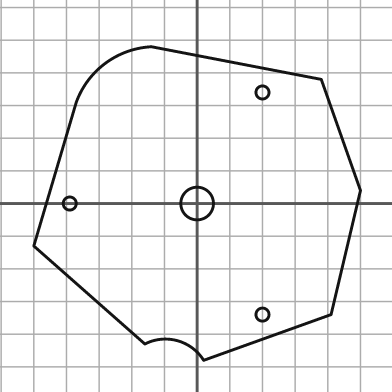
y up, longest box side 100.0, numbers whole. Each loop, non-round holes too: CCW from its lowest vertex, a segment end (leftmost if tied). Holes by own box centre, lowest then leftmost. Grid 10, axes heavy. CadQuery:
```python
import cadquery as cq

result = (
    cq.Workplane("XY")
    .moveTo(2.0, -48.0)
    .lineTo(41.0, -34.0)
    .lineTo(50.0, 4.0)
    .lineTo(38.0, 38.0)
    .lineTo(-14.0, 48.0)
    .threePointArc((-28.0, 43.0), (-37.0, 31.0))
    .lineTo(-50.0, -13.0)
    .lineTo(-16.0, -43.0)
    .threePointArc((-6.0, -42.0), (2.0, -48.0))
    .close()
    .moveTo(20.0, -34.0)
    .circle(2.0)
    .moveTo(-39.0, 0.0)
    .circle(2.0)
    .moveTo(0.0, 0.0)
    .circle(5.0)
    .moveTo(20.0, 34.0)
    .circle(2.0)
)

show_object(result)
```